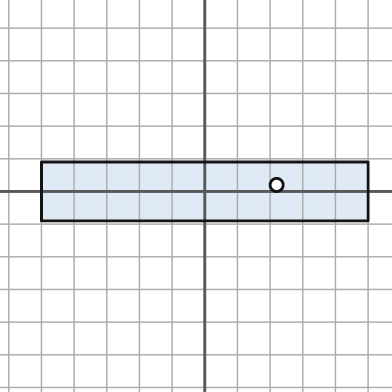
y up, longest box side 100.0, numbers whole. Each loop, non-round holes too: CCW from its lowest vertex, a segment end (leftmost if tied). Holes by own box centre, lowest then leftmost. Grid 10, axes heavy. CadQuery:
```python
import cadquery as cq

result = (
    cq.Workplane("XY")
    .moveTo(-50.0, -9.0)
    .lineTo(50.0, -9.0)
    .lineTo(50.0, 9.0)
    .lineTo(-50.0, 9.0)
    .close()
    .moveTo(22.0, 2.0)
    .circle(2.0)
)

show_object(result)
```